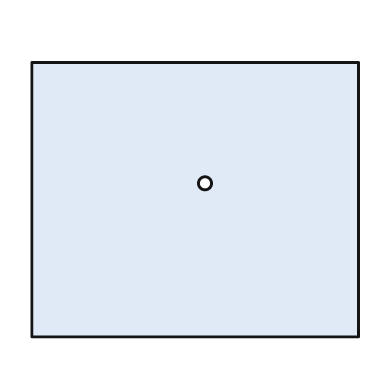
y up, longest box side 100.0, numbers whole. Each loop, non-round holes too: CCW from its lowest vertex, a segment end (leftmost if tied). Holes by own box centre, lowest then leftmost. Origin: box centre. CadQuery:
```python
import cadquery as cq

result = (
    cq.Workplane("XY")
    .moveTo(-50.0, -42.0)
    .lineTo(50.0, -42.0)
    .lineTo(50.0, 42.0)
    .lineTo(-50.0, 42.0)
    .close()
    .moveTo(3.0, 5.0)
    .circle(2.0)
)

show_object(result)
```